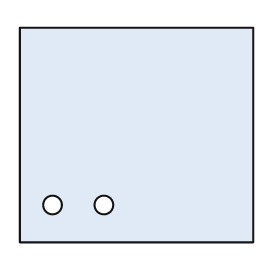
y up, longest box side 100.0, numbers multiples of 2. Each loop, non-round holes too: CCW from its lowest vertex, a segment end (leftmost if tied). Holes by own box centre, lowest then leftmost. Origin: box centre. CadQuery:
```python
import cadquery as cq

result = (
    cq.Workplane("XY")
    .moveTo(-50.0, -46.0)
    .lineTo(50.0, -46.0)
    .lineTo(50.0, 46.0)
    .lineTo(-50.0, 46.0)
    .close()
    .moveTo(-36.0, -30.0)
    .circle(4.0)
    .moveTo(-14.0, -30.0)
    .circle(4.0)
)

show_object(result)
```